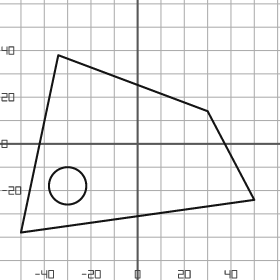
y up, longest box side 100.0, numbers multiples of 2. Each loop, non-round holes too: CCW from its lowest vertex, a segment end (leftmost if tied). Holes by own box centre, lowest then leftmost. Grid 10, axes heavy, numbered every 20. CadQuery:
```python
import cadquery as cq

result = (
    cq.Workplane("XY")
    .moveTo(-50.0, -38.0)
    .lineTo(50.0, -24.0)
    .lineTo(30.0, 14.0)
    .lineTo(-34.0, 38.0)
    .close()
    .moveTo(-30.0, -18.0)
    .circle(8.0)
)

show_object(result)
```